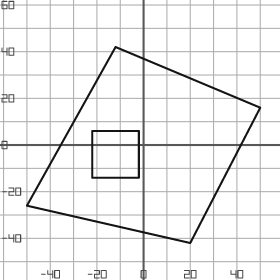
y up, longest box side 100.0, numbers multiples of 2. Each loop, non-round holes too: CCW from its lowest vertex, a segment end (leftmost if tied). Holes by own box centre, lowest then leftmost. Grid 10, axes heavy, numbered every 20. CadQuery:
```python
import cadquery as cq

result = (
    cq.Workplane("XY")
    .moveTo(20.0, -42.0)
    .lineTo(50.0, 16.0)
    .lineTo(-12.0, 42.0)
    .lineTo(-50.0, -26.0)
    .close()
    .moveTo(-22.0, -14.0)
    .lineTo(-2.0, -14.0)
    .lineTo(-2.0, 6.0)
    .lineTo(-22.0, 6.0)
    .close()
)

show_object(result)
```